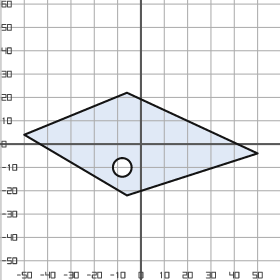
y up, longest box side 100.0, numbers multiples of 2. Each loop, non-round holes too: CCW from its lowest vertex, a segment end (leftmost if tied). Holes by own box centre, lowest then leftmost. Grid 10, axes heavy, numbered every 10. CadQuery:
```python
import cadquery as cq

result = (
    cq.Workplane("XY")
    .moveTo(-6.0, -22.0)
    .lineTo(50.0, -4.0)
    .lineTo(-6.0, 22.0)
    .lineTo(-50.0, 4.0)
    .close()
    .moveTo(-8.0, -10.0)
    .circle(4.0)
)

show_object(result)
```